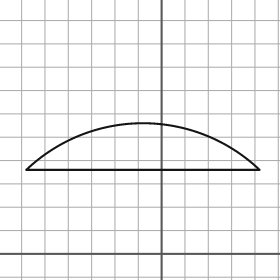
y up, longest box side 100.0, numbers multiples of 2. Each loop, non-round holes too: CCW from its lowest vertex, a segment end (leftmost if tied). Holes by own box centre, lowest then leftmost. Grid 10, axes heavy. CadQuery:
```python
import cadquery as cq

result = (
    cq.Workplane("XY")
    .moveTo(-58.0, 36.0)
    .lineTo(42.0, 36.0)
    .threePointArc((-8.0, 56.0), (-58.0, 36.0))
    .close()
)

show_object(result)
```